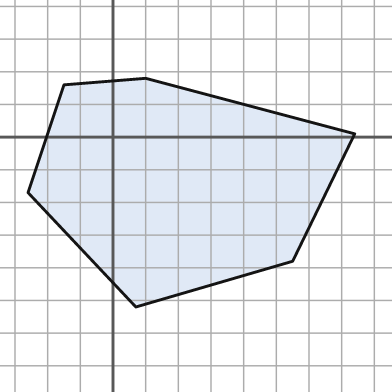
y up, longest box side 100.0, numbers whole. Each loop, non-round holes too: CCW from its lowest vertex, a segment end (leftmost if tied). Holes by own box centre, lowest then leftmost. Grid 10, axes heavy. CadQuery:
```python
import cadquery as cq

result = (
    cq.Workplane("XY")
    .moveTo(7.0, -52.0)
    .lineTo(55.0, -38.0)
    .lineTo(74.0, 1.0)
    .lineTo(10.0, 18.0)
    .lineTo(-15.0, 16.0)
    .lineTo(-26.0, -17.0)
    .close()
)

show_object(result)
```